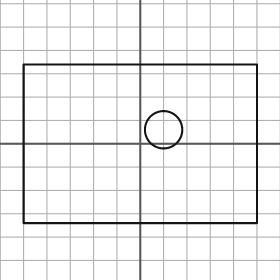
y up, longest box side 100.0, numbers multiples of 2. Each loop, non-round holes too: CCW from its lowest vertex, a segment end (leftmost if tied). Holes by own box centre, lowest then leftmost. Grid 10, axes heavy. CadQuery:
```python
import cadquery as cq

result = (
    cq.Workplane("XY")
    .moveTo(-50.0, -34.0)
    .lineTo(50.0, -34.0)
    .lineTo(50.0, 34.0)
    .lineTo(-50.0, 34.0)
    .close()
    .moveTo(10.0, 6.0)
    .circle(8.0)
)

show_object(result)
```